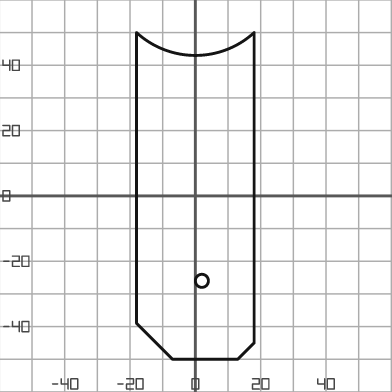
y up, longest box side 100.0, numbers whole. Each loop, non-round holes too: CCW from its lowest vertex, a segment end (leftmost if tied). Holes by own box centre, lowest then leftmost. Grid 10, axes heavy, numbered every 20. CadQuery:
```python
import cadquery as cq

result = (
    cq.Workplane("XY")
    .moveTo(-7.0, -50.0)
    .lineTo(13.0, -50.0)
    .lineTo(18.0, -45.0)
    .lineTo(18.0, 50.0)
    .threePointArc((0.0, 43.0), (-18.0, 50.0))
    .lineTo(-18.0, -39.0)
    .close()
    .moveTo(2.0, -26.0)
    .circle(2.0)
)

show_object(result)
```